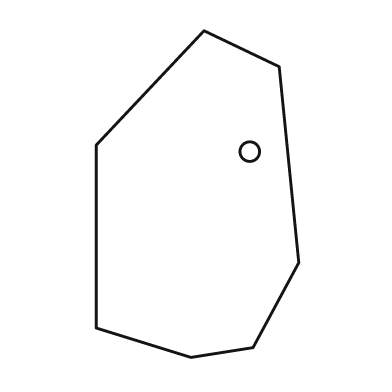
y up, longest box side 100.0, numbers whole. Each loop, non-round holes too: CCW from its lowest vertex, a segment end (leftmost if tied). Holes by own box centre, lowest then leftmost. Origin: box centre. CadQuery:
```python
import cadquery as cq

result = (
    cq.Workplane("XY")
    .moveTo(-2.0, -50.0)
    .lineTo(17.0, -47.0)
    .lineTo(31.0, -21.0)
    .lineTo(25.0, 39.0)
    .lineTo(2.0, 50.0)
    .lineTo(-31.0, 15.0)
    .lineTo(-31.0, -41.0)
    .close()
    .moveTo(16.0, 13.0)
    .circle(3.0)
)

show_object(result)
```